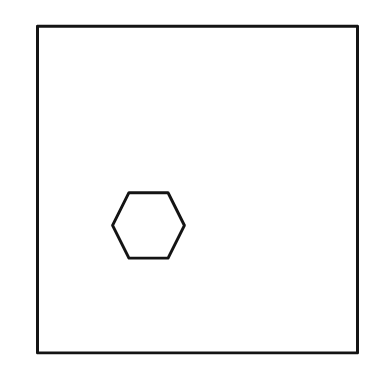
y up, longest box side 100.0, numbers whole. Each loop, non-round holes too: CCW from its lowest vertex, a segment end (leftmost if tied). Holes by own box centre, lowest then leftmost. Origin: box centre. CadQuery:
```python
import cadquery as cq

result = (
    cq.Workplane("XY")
    .moveTo(-49.0, -50.0)
    .lineTo(49.0, -50.0)
    .lineTo(49.0, 50.0)
    .lineTo(-49.0, 50.0)
    .close()
    .moveTo(-21.0, -21.0)
    .lineTo(-9.0, -21.0)
    .lineTo(-4.0, -11.0)
    .lineTo(-9.0, -1.0)
    .lineTo(-21.0, -1.0)
    .lineTo(-26.0, -11.0)
    .close()
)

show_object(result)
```